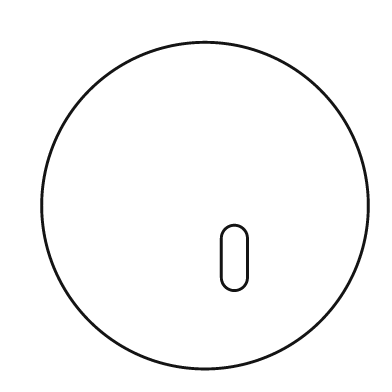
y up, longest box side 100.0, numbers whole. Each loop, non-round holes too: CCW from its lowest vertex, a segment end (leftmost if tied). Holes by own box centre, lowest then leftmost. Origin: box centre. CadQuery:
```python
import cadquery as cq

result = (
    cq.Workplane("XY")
    .moveTo(0.0, 0.0)
    .circle(50.0)
    .moveTo(5.0, -22.0)
    .threePointArc((9.0, -26.0), (13.0, -22.0))
    .lineTo(13.0, -10.0)
    .threePointArc((9.0, -6.0), (5.0, -10.0))
    .close()
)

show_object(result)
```